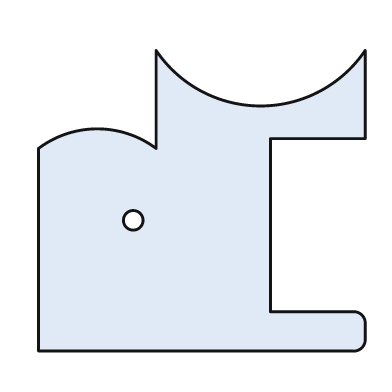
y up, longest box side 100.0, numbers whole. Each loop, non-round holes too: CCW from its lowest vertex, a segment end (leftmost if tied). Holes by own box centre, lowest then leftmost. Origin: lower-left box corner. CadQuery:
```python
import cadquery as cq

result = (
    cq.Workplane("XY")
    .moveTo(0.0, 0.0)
    .lineTo(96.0, 0.0)
    .threePointArc((99.0, 1.0), (100.0, 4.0))
    .lineTo(100.0, 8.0)
    .threePointArc((99.0, 11.0), (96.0, 12.0))
    .lineTo(71.0, 12.0)
    .lineTo(71.0, 65.0)
    .lineTo(100.0, 65.0)
    .lineTo(100.0, 92.0)
    .threePointArc((68.0, 75.0), (36.0, 92.0))
    .lineTo(36.0, 62.0)
    .threePointArc((18.0, 68.0), (0.0, 62.0))
    .close()
    .moveTo(29.0, 40.0)
    .circle(3.0)
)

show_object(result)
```